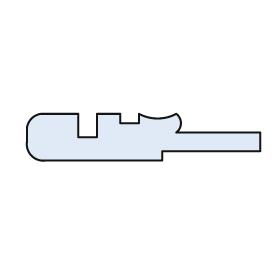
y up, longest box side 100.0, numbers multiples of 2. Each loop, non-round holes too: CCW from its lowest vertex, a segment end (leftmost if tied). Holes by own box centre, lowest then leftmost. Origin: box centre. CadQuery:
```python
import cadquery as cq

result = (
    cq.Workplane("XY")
    .moveTo(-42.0, -10.0)
    .lineTo(8.0, -10.0)
    .lineTo(8.0, -6.0)
    .lineTo(50.0, -6.0)
    .lineTo(50.0, 2.0)
    .lineTo(14.0, 2.0)
    .threePointArc((16.0, 6.0), (14.0, 10.0))
    .threePointArc((6.0, 8.0), (-2.0, 10.0))
    .lineTo(-2.0, 6.0)
    .lineTo(-10.0, 6.0)
    .lineTo(-10.0, 10.0)
    .lineTo(-20.0, 10.0)
    .lineTo(-20.0, 0.0)
    .lineTo(-28.0, 0.0)
    .lineTo(-28.0, 10.0)
    .lineTo(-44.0, 10.0)
    .threePointArc((-48.0, 8.0), (-50.0, 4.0))
    .lineTo(-50.0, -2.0)
    .threePointArc((-48.0, -8.0), (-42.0, -10.0))
    .close()
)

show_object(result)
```